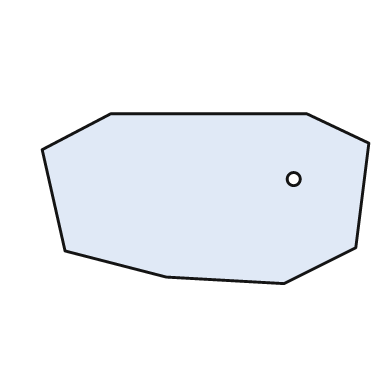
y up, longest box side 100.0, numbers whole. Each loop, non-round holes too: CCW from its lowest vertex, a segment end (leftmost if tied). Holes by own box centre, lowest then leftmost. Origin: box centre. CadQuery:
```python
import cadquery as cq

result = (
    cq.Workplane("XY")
    .moveTo(24.0, -26.0)
    .lineTo(46.0, -15.0)
    .lineTo(50.0, 17.0)
    .lineTo(31.0, 26.0)
    .lineTo(-29.0, 26.0)
    .lineTo(-50.0, 15.0)
    .lineTo(-43.0, -16.0)
    .lineTo(-12.0, -24.0)
    .close()
    .moveTo(27.0, 6.0)
    .circle(2.0)
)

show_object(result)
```